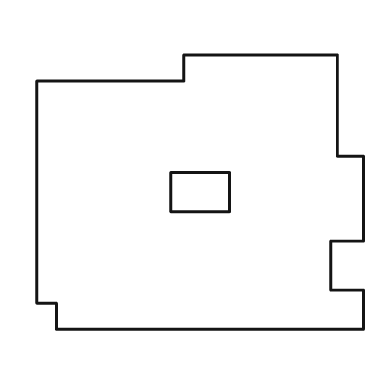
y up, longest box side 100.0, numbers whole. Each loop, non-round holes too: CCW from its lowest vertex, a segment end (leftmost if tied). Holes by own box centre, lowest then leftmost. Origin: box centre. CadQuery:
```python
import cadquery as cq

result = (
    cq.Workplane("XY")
    .moveTo(-44.0, -42.0)
    .lineTo(50.0, -42.0)
    .lineTo(50.0, -30.0)
    .lineTo(40.0, -30.0)
    .lineTo(40.0, -15.0)
    .lineTo(50.0, -15.0)
    .lineTo(50.0, 11.0)
    .lineTo(42.0, 11.0)
    .lineTo(42.0, 42.0)
    .lineTo(-5.0, 42.0)
    .lineTo(-5.0, 34.0)
    .lineTo(-50.0, 34.0)
    .lineTo(-50.0, -34.0)
    .lineTo(-44.0, -34.0)
    .close()
    .moveTo(-9.0, -6.0)
    .lineTo(9.0, -6.0)
    .lineTo(9.0, 6.0)
    .lineTo(-9.0, 6.0)
    .close()
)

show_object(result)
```